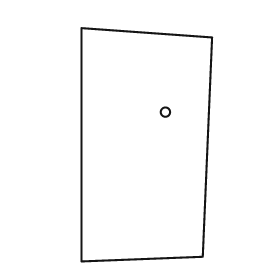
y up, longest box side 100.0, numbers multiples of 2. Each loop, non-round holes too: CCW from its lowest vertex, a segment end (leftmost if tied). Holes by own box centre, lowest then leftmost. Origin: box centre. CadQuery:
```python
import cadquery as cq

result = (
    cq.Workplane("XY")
    .moveTo(-28.0, -50.0)
    .lineTo(24.0, -48.0)
    .lineTo(28.0, 46.0)
    .lineTo(-28.0, 50.0)
    .close()
    .moveTo(8.0, 14.0)
    .circle(2.0)
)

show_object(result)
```